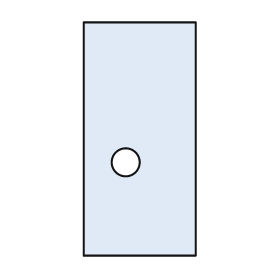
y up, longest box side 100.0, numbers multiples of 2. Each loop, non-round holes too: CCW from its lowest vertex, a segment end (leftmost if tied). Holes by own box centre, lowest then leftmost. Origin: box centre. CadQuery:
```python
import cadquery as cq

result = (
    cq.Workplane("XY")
    .moveTo(-24.0, -50.0)
    .lineTo(24.0, -50.0)
    .lineTo(24.0, 50.0)
    .lineTo(-24.0, 50.0)
    .close()
    .moveTo(-6.0, -10.0)
    .circle(6.0)
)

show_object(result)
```